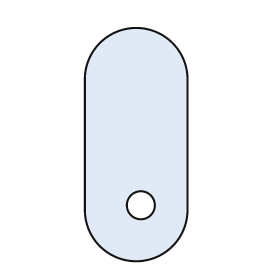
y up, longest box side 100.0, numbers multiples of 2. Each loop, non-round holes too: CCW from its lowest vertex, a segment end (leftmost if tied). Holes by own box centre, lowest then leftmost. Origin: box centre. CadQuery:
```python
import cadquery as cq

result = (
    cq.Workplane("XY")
    .moveTo(-22.0, -28.0)
    .threePointArc((0.0, -50.0), (22.0, -28.0))
    .lineTo(22.0, 28.0)
    .threePointArc((0.0, 50.0), (-22.0, 28.0))
    .close()
    .moveTo(2.0, -26.0)
    .circle(6.0)
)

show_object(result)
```